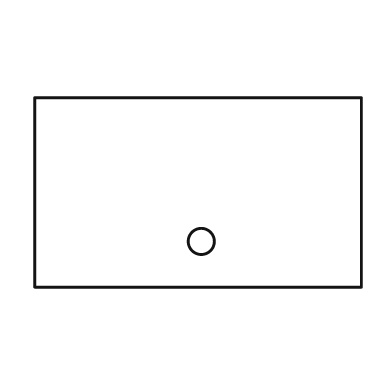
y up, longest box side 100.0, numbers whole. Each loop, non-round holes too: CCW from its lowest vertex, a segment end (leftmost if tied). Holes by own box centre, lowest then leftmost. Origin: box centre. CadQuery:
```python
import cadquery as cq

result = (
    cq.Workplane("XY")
    .moveTo(-50.0, -29.0)
    .lineTo(50.0, -29.0)
    .lineTo(50.0, 29.0)
    .lineTo(-50.0, 29.0)
    .close()
    .moveTo(1.0, -15.0)
    .circle(4.0)
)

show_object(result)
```